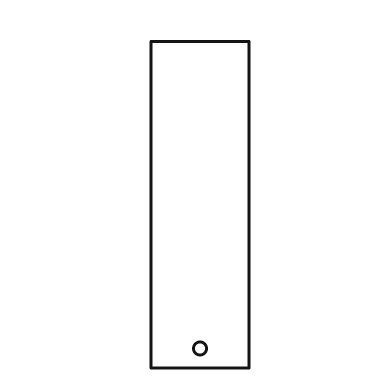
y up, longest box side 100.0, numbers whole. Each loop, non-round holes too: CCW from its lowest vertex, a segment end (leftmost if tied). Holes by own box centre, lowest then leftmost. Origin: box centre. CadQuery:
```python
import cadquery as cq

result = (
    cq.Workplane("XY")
    .moveTo(-15.0, -50.0)
    .lineTo(15.0, -50.0)
    .lineTo(15.0, 50.0)
    .lineTo(-15.0, 50.0)
    .close()
    .moveTo(0.0, -44.0)
    .circle(2.0)
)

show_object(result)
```